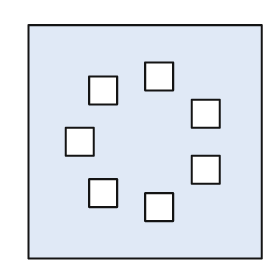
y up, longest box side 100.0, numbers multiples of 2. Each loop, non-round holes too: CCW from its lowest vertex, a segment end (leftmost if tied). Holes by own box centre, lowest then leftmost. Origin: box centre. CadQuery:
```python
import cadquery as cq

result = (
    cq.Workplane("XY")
    .moveTo(-50.0, -50.0)
    .lineTo(50.0, -50.0)
    .lineTo(50.0, 50.0)
    .lineTo(-50.0, 50.0)
    .close()
    .moveTo(0.0, -34.0)
    .lineTo(12.0, -34.0)
    .lineTo(12.0, -22.0)
    .lineTo(0.0, -22.0)
    .close()
    .moveTo(-24.0, -28.0)
    .lineTo(-12.0, -28.0)
    .lineTo(-12.0, -16.0)
    .lineTo(-24.0, -16.0)
    .close()
    .moveTo(20.0, -18.0)
    .lineTo(32.0, -18.0)
    .lineTo(32.0, -6.0)
    .lineTo(20.0, -6.0)
    .close()
    .moveTo(-34.0, -6.0)
    .lineTo(-22.0, -6.0)
    .lineTo(-22.0, 6.0)
    .lineTo(-34.0, 6.0)
    .close()
    .moveTo(20.0, 6.0)
    .lineTo(32.0, 6.0)
    .lineTo(32.0, 18.0)
    .lineTo(20.0, 18.0)
    .close()
    .moveTo(-24.0, 16.0)
    .lineTo(-12.0, 16.0)
    .lineTo(-12.0, 28.0)
    .lineTo(-24.0, 28.0)
    .close()
    .moveTo(0.0, 22.0)
    .lineTo(12.0, 22.0)
    .lineTo(12.0, 34.0)
    .lineTo(0.0, 34.0)
    .close()
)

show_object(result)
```